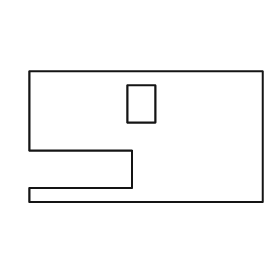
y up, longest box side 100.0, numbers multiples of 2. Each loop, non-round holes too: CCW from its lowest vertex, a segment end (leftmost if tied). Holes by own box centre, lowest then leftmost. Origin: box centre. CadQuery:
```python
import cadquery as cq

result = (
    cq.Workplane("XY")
    .moveTo(-50.0, -28.0)
    .lineTo(50.0, -28.0)
    .lineTo(50.0, 28.0)
    .lineTo(-50.0, 28.0)
    .lineTo(-50.0, -6.0)
    .lineTo(-6.0, -6.0)
    .lineTo(-6.0, -22.0)
    .lineTo(-50.0, -22.0)
    .close()
    .moveTo(-8.0, 6.0)
    .lineTo(4.0, 6.0)
    .lineTo(4.0, 22.0)
    .lineTo(-8.0, 22.0)
    .close()
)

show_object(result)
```